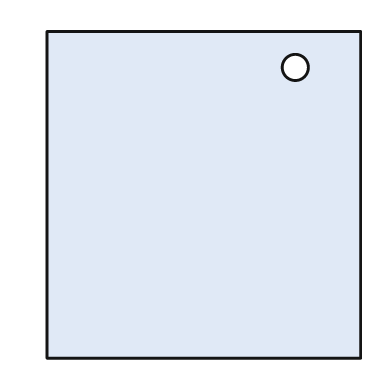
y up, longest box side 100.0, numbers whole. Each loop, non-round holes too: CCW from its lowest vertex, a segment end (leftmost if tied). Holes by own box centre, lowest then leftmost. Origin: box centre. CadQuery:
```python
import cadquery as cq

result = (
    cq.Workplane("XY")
    .moveTo(-48.0, -50.0)
    .lineTo(48.0, -50.0)
    .lineTo(48.0, 50.0)
    .lineTo(-48.0, 50.0)
    .close()
    .moveTo(28.0, 39.0)
    .circle(4.0)
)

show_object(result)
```